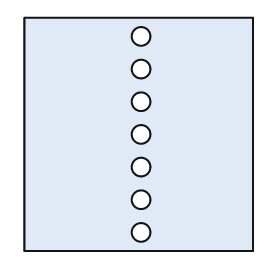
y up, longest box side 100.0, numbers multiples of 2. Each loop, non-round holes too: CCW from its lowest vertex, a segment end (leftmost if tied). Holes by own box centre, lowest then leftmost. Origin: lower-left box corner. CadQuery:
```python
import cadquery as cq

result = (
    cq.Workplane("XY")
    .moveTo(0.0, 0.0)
    .lineTo(98.0, 0.0)
    .lineTo(98.0, 100.0)
    .lineTo(0.0, 100.0)
    .close()
    .moveTo(50.0, 8.0)
    .circle(4.0)
    .moveTo(50.0, 22.0)
    .circle(4.0)
    .moveTo(50.0, 36.0)
    .circle(4.0)
    .moveTo(50.0, 50.0)
    .circle(4.0)
    .moveTo(50.0, 64.0)
    .circle(4.0)
    .moveTo(50.0, 78.0)
    .circle(4.0)
    .moveTo(50.0, 92.0)
    .circle(4.0)
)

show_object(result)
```